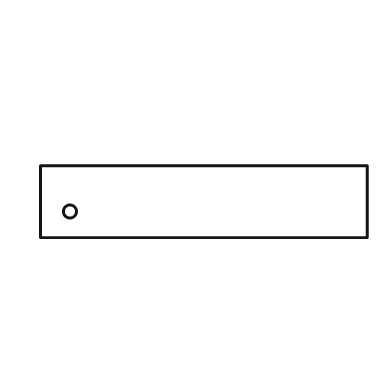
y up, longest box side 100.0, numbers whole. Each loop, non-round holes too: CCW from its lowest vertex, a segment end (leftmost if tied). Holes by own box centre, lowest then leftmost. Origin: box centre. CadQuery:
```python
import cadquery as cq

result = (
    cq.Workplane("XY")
    .moveTo(-50.0, -11.0)
    .lineTo(50.0, -11.0)
    .lineTo(50.0, 11.0)
    .lineTo(-50.0, 11.0)
    .close()
    .moveTo(-41.0, -3.0)
    .circle(2.0)
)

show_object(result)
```